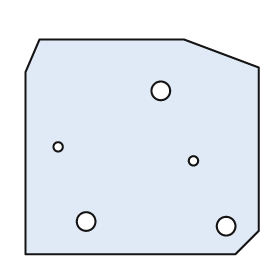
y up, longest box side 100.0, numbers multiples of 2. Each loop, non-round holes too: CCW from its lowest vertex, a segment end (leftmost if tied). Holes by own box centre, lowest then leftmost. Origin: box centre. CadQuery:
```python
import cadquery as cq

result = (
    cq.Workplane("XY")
    .moveTo(-50.0, -46.0)
    .lineTo(40.0, -46.0)
    .lineTo(50.0, -36.0)
    .lineTo(50.0, 34.0)
    .lineTo(18.0, 46.0)
    .lineTo(-44.0, 46.0)
    .lineTo(-50.0, 32.0)
    .close()
    .moveTo(36.0, -34.0)
    .circle(4.0)
    .moveTo(-24.0, -32.0)
    .circle(4.0)
    .moveTo(22.0, -6.0)
    .circle(2.0)
    .moveTo(-36.0, 0.0)
    .circle(2.0)
    .moveTo(8.0, 24.0)
    .circle(4.0)
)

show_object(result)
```